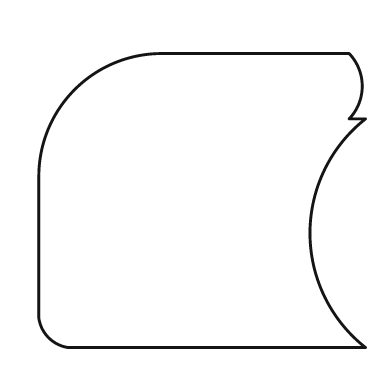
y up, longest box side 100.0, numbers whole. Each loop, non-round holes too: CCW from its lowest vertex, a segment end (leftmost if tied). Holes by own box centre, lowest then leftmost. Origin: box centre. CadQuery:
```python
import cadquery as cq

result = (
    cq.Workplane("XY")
    .moveTo(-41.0, -45.0)
    .lineTo(50.0, -45.0)
    .threePointArc((33.0, -10.0), (50.0, 25.0))
    .lineTo(45.0, 25.0)
    .threePointArc((49.0, 35.0), (45.0, 45.0))
    .lineTo(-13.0, 45.0)
    .threePointArc((-39.0, 34.0), (-50.0, 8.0))
    .lineTo(-50.0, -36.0)
    .threePointArc((-47.0, -42.0), (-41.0, -45.0))
    .close()
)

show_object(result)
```